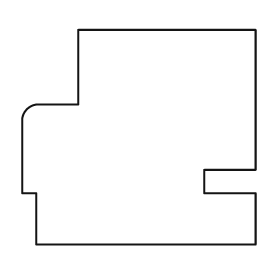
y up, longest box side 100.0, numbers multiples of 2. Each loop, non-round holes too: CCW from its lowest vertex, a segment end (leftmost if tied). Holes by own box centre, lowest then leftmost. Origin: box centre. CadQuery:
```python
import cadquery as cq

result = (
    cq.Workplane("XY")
    .moveTo(-44.0, -46.0)
    .lineTo(50.0, -46.0)
    .lineTo(50.0, -24.0)
    .lineTo(28.0, -24.0)
    .lineTo(28.0, -14.0)
    .lineTo(50.0, -14.0)
    .lineTo(50.0, 46.0)
    .lineTo(-26.0, 46.0)
    .lineTo(-26.0, 14.0)
    .lineTo(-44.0, 14.0)
    .threePointArc((-48.0, 12.0), (-50.0, 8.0))
    .lineTo(-50.0, -24.0)
    .lineTo(-44.0, -24.0)
    .close()
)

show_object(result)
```